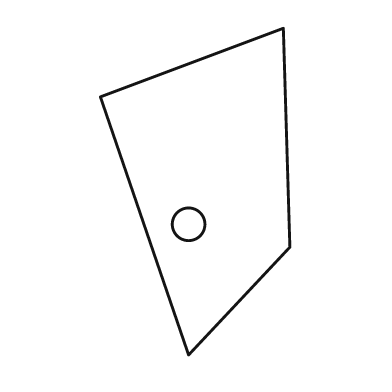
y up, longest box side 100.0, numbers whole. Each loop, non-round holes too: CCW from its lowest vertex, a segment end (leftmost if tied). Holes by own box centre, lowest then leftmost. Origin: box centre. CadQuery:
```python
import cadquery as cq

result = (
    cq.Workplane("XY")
    .moveTo(-2.0, -50.0)
    .lineTo(29.0, -17.0)
    .lineTo(27.0, 50.0)
    .lineTo(-29.0, 29.0)
    .close()
    .moveTo(-2.0, -10.0)
    .circle(5.0)
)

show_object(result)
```